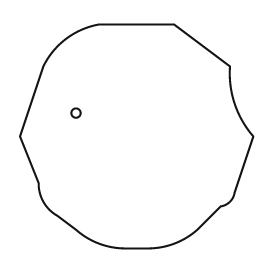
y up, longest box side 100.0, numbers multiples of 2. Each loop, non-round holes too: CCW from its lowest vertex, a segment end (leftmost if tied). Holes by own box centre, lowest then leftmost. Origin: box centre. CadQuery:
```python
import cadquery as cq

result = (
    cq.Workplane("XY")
    .moveTo(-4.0, -48.0)
    .lineTo(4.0, -48.0)
    .threePointArc((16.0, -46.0), (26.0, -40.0))
    .lineTo(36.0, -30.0)
    .threePointArc((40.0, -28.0), (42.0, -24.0))
    .lineTo(50.0, 0.0)
    .threePointArc((42.0, 14.0), (40.0, 30.0))
    .lineTo(16.0, 48.0)
    .lineTo(-16.0, 48.0)
    .threePointArc((-30.0, 42.0), (-40.0, 30.0))
    .lineTo(-50.0, 0.0)
    .lineTo(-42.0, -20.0)
    .threePointArc((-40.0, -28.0), (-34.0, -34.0))
    .lineTo(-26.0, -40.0)
    .threePointArc((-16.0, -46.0), (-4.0, -48.0))
    .close()
    .moveTo(-26.0, 10.0)
    .circle(2.0)
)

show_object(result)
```